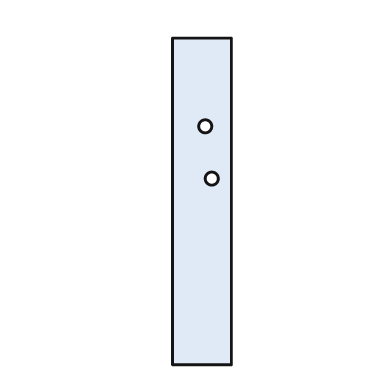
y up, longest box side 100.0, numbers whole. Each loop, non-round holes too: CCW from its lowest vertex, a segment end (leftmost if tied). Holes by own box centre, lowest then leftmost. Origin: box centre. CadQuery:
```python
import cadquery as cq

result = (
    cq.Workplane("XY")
    .moveTo(-9.0, -50.0)
    .lineTo(9.0, -50.0)
    .lineTo(9.0, 50.0)
    .lineTo(-9.0, 50.0)
    .close()
    .moveTo(3.0, 7.0)
    .circle(2.0)
    .moveTo(1.0, 23.0)
    .circle(2.0)
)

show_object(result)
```